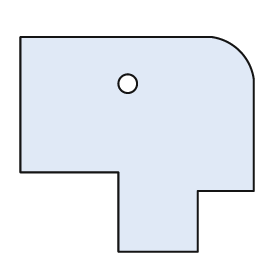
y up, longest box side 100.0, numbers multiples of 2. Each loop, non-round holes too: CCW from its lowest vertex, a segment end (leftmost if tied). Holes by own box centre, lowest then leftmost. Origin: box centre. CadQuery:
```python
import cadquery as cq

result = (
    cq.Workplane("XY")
    .moveTo(-8.0, -46.0)
    .lineTo(26.0, -46.0)
    .lineTo(26.0, -20.0)
    .lineTo(50.0, -20.0)
    .lineTo(50.0, 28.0)
    .threePointArc((44.0, 40.0), (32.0, 46.0))
    .lineTo(-50.0, 46.0)
    .lineTo(-50.0, -12.0)
    .lineTo(-8.0, -12.0)
    .close()
    .moveTo(-4.0, 26.0)
    .circle(4.0)
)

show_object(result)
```